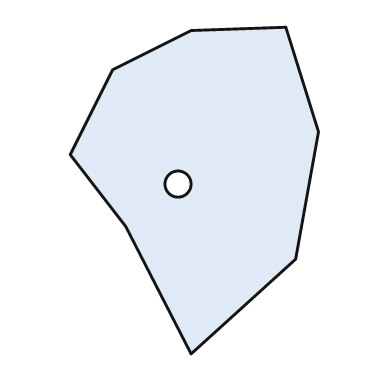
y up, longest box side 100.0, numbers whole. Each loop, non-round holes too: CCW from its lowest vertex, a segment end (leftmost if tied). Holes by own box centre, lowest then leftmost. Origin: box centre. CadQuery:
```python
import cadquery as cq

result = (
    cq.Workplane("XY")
    .moveTo(-1.0, -50.0)
    .lineTo(31.0, -21.0)
    .lineTo(38.0, 18.0)
    .lineTo(28.0, 50.0)
    .lineTo(-1.0, 49.0)
    .lineTo(-25.0, 37.0)
    .lineTo(-38.0, 11.0)
    .lineTo(-21.0, -11.0)
    .close()
    .moveTo(-5.0, 2.0)
    .circle(4.0)
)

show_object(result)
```